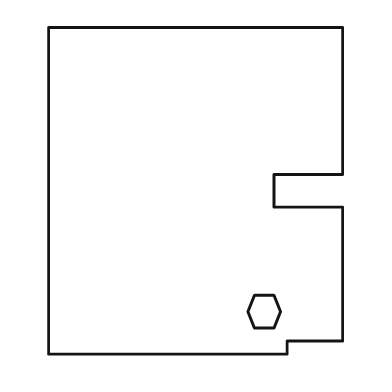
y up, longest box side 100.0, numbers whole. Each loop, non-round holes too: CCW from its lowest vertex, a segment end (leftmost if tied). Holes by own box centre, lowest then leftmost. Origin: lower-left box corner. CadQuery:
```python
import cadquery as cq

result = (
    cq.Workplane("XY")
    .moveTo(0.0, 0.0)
    .lineTo(73.0, 0.0)
    .lineTo(73.0, 4.0)
    .lineTo(90.0, 4.0)
    .lineTo(90.0, 45.0)
    .lineTo(69.0, 45.0)
    .lineTo(69.0, 55.0)
    .lineTo(90.0, 55.0)
    .lineTo(90.0, 100.0)
    .lineTo(0.0, 100.0)
    .close()
    .moveTo(63.0, 8.0)
    .lineTo(69.0, 8.0)
    .lineTo(71.0, 13.0)
    .lineTo(69.0, 18.0)
    .lineTo(63.0, 18.0)
    .lineTo(61.0, 13.0)
    .close()
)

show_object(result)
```